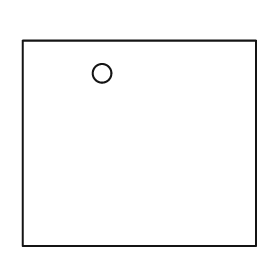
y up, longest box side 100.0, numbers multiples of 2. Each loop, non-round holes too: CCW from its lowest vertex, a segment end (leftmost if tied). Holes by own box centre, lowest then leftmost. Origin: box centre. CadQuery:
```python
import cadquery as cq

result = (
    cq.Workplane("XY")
    .moveTo(-50.0, -44.0)
    .lineTo(50.0, -44.0)
    .lineTo(50.0, 44.0)
    .lineTo(-50.0, 44.0)
    .close()
    .moveTo(-16.0, 30.0)
    .circle(4.0)
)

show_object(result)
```